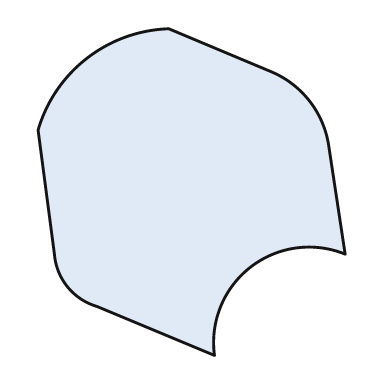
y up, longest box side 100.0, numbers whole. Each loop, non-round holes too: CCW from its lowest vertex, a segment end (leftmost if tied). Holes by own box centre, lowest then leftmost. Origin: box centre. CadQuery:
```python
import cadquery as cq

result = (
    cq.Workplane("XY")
    .moveTo(7.0, -50.0)
    .threePointArc((18.0, -23.0), (47.0, -19.0))
    .lineTo(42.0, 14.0)
    .threePointArc((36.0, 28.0), (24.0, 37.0))
    .lineTo(-7.0, 50.0)
    .threePointArc((-32.0, 41.0), (-47.0, 19.0))
    .lineTo(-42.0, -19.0)
    .threePointArc((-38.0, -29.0), (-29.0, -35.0))
    .close()
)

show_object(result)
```